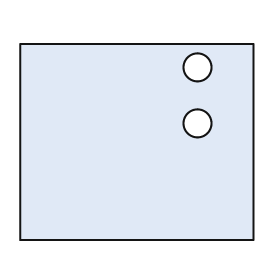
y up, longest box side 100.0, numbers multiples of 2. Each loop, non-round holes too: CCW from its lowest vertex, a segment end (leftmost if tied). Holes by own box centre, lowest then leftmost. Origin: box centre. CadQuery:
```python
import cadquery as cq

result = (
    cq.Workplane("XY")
    .moveTo(-50.0, -42.0)
    .lineTo(50.0, -42.0)
    .lineTo(50.0, 42.0)
    .lineTo(-50.0, 42.0)
    .close()
    .moveTo(26.0, 8.0)
    .circle(6.0)
    .moveTo(26.0, 32.0)
    .circle(6.0)
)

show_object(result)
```